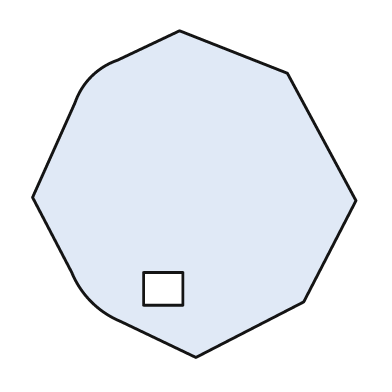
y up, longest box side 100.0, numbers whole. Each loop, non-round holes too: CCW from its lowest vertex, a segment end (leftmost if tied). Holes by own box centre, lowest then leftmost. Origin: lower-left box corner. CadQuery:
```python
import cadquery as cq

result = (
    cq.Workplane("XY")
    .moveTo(50.0, 0.0)
    .lineTo(83.0, 17.0)
    .lineTo(99.0, 48.0)
    .lineTo(78.0, 87.0)
    .lineTo(45.0, 100.0)
    .lineTo(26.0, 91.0)
    .threePointArc((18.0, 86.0), (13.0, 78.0))
    .lineTo(0.0, 49.0)
    .lineTo(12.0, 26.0)
    .threePointArc((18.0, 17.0), (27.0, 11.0))
    .close()
    .moveTo(34.0, 16.0)
    .lineTo(46.0, 16.0)
    .lineTo(46.0, 26.0)
    .lineTo(34.0, 26.0)
    .close()
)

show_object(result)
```